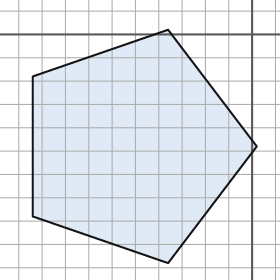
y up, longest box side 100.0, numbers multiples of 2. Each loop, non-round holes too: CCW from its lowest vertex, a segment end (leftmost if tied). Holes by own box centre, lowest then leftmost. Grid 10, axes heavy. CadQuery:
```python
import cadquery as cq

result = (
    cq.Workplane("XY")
    .moveTo(-36.0, -98.0)
    .lineTo(2.0, -48.0)
    .lineTo(-36.0, 2.0)
    .lineTo(-94.0, -18.0)
    .lineTo(-94.0, -78.0)
    .close()
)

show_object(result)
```